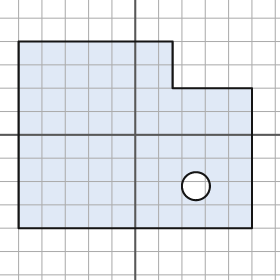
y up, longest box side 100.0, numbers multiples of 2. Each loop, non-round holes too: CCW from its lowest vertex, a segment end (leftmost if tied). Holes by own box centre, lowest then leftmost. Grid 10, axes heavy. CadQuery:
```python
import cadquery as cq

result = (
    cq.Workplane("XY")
    .moveTo(-50.0, -40.0)
    .lineTo(50.0, -40.0)
    .lineTo(50.0, 20.0)
    .lineTo(16.0, 20.0)
    .lineTo(16.0, 40.0)
    .lineTo(-50.0, 40.0)
    .close()
    .moveTo(26.0, -22.0)
    .circle(6.0)
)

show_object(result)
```